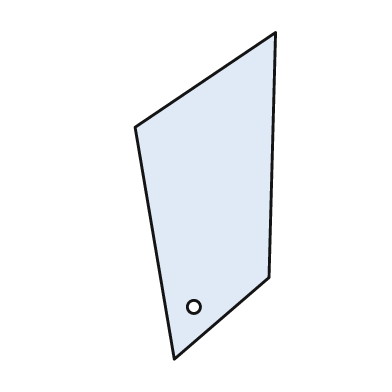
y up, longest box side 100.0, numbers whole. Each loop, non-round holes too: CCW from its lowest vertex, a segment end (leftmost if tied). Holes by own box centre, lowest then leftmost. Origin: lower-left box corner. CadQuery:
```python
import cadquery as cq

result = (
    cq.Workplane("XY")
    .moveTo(12.0, 0.0)
    .lineTo(41.0, 25.0)
    .lineTo(43.0, 100.0)
    .lineTo(0.0, 71.0)
    .close()
    .moveTo(18.0, 16.0)
    .circle(2.0)
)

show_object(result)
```